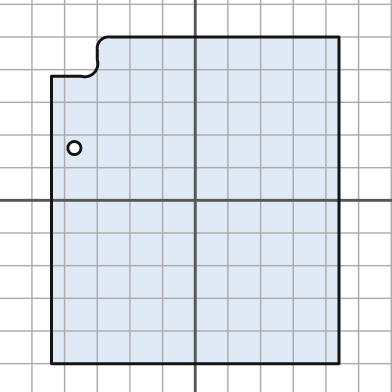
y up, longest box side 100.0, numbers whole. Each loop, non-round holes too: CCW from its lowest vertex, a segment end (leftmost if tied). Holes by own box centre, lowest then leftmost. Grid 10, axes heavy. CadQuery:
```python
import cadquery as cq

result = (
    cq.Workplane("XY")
    .moveTo(-44.0, -50.0)
    .lineTo(44.0, -50.0)
    .lineTo(44.0, 50.0)
    .lineTo(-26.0, 50.0)
    .threePointArc((-29.0, 49.0), (-30.0, 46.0))
    .lineTo(-30.0, 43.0)
    .threePointArc((-31.0, 39.0), (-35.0, 38.0))
    .lineTo(-44.0, 38.0)
    .close()
    .moveTo(-37.0, 16.0)
    .circle(2.0)
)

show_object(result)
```